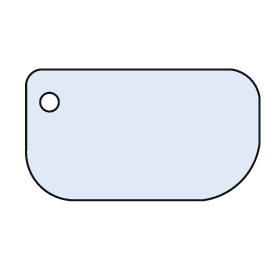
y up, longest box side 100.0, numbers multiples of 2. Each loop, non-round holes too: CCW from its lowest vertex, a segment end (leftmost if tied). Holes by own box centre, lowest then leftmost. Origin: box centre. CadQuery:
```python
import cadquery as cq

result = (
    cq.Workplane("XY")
    .moveTo(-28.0, -28.0)
    .lineTo(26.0, -28.0)
    .threePointArc((42.0, -20.0), (50.0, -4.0))
    .lineTo(50.0, 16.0)
    .threePointArc((46.0, 24.0), (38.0, 28.0))
    .lineTo(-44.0, 28.0)
    .threePointArc((-48.0, 26.0), (-50.0, 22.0))
    .lineTo(-50.0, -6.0)
    .threePointArc((-44.0, -22.0), (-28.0, -28.0))
    .close()
    .moveTo(-40.0, 14.0)
    .circle(4.0)
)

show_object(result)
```